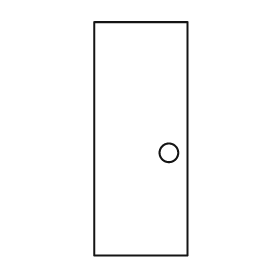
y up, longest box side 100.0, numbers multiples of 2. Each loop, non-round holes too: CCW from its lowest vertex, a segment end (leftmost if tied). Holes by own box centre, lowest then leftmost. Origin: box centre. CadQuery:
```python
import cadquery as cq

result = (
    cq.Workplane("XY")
    .moveTo(-20.0, -50.0)
    .lineTo(20.0, -50.0)
    .lineTo(20.0, 50.0)
    .lineTo(-20.0, 50.0)
    .close()
    .moveTo(12.0, -6.0)
    .circle(4.0)
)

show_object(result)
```